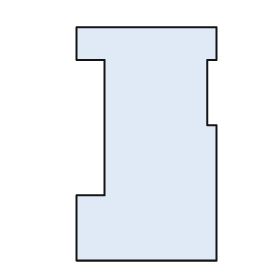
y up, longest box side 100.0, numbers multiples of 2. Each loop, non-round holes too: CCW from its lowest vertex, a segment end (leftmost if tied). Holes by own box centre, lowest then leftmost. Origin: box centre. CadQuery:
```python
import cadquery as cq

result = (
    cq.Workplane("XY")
    .moveTo(-30.0, -50.0)
    .lineTo(30.0, -50.0)
    .lineTo(30.0, 8.0)
    .lineTo(26.0, 8.0)
    .lineTo(26.0, 36.0)
    .lineTo(30.0, 36.0)
    .lineTo(30.0, 50.0)
    .lineTo(-30.0, 50.0)
    .lineTo(-30.0, 36.0)
    .lineTo(-18.0, 36.0)
    .lineTo(-18.0, -22.0)
    .lineTo(-30.0, -22.0)
    .close()
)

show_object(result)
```